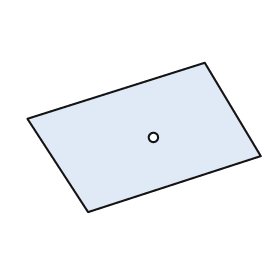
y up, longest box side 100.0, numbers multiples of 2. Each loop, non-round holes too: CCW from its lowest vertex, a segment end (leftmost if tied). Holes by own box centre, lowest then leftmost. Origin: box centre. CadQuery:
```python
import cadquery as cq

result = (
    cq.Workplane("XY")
    .moveTo(-24.0, -32.0)
    .lineTo(50.0, -8.0)
    .lineTo(26.0, 32.0)
    .lineTo(-50.0, 8.0)
    .close()
    .moveTo(4.0, 0.0)
    .circle(2.0)
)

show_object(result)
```